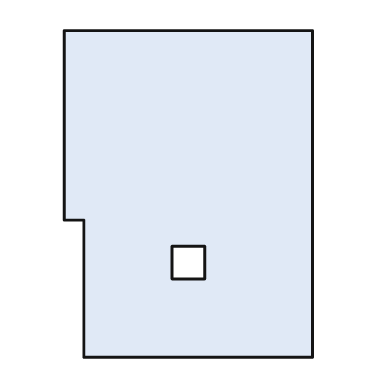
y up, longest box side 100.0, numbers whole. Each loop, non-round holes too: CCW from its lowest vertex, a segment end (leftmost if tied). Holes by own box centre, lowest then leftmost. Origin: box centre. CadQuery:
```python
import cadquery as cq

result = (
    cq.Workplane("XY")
    .moveTo(-32.0, -50.0)
    .lineTo(38.0, -50.0)
    .lineTo(38.0, 50.0)
    .lineTo(-38.0, 50.0)
    .lineTo(-38.0, -8.0)
    .lineTo(-32.0, -8.0)
    .close()
    .moveTo(-5.0, -26.0)
    .lineTo(5.0, -26.0)
    .lineTo(5.0, -16.0)
    .lineTo(-5.0, -16.0)
    .close()
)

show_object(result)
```